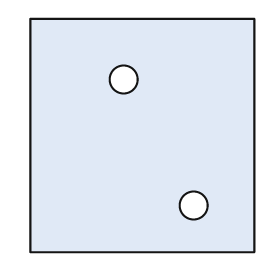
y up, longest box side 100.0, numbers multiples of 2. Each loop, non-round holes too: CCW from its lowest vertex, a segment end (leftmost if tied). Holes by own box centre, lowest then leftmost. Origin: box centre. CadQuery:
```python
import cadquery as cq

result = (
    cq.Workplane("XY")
    .moveTo(-48.0, -50.0)
    .lineTo(48.0, -50.0)
    .lineTo(48.0, 50.0)
    .lineTo(-48.0, 50.0)
    .close()
    .moveTo(22.0, -30.0)
    .circle(6.0)
    .moveTo(-8.0, 24.0)
    .circle(6.0)
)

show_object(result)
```